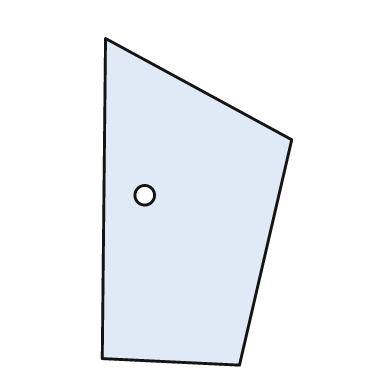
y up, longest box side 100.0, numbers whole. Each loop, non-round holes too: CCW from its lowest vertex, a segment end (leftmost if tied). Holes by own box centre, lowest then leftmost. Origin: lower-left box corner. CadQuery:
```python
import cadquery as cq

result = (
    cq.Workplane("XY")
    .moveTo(42.0, 0.0)
    .lineTo(58.0, 69.0)
    .lineTo(1.0, 100.0)
    .lineTo(0.0, 2.0)
    .close()
    .moveTo(13.0, 52.0)
    .circle(3.0)
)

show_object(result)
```